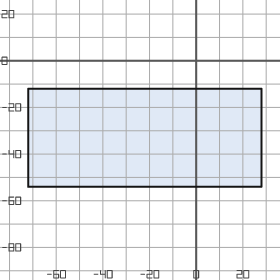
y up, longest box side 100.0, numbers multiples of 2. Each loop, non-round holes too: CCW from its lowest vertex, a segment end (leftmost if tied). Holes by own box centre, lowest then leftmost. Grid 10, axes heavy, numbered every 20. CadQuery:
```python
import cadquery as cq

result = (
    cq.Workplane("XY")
    .moveTo(-72.0, -54.0)
    .lineTo(28.0, -54.0)
    .lineTo(28.0, -12.0)
    .lineTo(-72.0, -12.0)
    .close()
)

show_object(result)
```